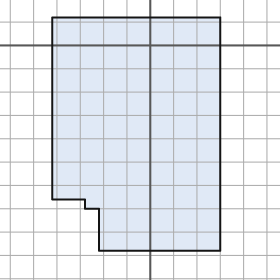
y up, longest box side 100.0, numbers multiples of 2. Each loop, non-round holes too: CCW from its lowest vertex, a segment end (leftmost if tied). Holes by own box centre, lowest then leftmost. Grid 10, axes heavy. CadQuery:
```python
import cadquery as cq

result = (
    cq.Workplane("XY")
    .moveTo(-22.0, -88.0)
    .lineTo(30.0, -88.0)
    .lineTo(30.0, 12.0)
    .lineTo(-42.0, 12.0)
    .lineTo(-42.0, -66.0)
    .lineTo(-28.0, -66.0)
    .lineTo(-28.0, -70.0)
    .lineTo(-22.0, -70.0)
    .close()
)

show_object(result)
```